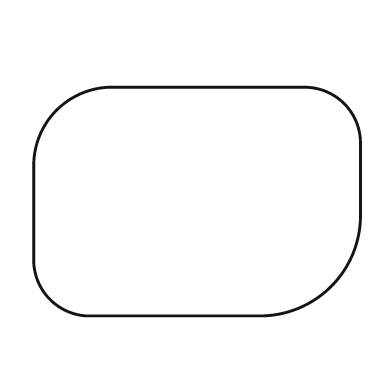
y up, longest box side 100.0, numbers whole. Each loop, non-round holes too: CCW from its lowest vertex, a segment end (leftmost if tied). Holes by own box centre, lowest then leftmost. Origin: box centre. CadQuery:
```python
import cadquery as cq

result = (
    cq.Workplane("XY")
    .moveTo(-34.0, -35.0)
    .lineTo(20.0, -35.0)
    .threePointArc((41.0, -26.0), (50.0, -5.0))
    .lineTo(50.0, 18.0)
    .threePointArc((45.0, 30.0), (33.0, 35.0))
    .lineTo(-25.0, 35.0)
    .threePointArc((-43.0, 28.0), (-50.0, 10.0))
    .lineTo(-50.0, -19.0)
    .threePointArc((-45.0, -30.0), (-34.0, -35.0))
    .close()
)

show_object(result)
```